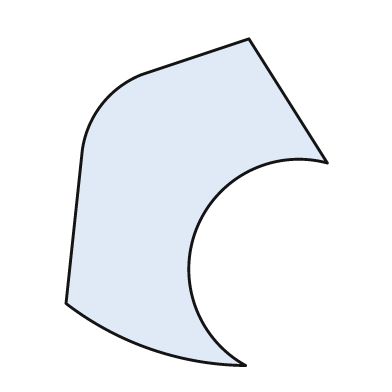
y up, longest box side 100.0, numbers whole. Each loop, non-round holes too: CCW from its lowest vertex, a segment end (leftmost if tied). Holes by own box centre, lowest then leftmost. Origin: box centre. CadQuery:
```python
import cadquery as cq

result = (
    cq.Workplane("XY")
    .moveTo(15.0, -50.0)
    .threePointArc((0.0, -8.0), (40.0, 12.0))
    .lineTo(16.0, 50.0)
    .lineTo(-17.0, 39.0)
    .threePointArc((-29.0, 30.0), (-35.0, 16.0))
    .lineTo(-40.0, -31.0)
    .threePointArc((-14.0, -45.0), (15.0, -50.0))
    .close()
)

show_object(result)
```